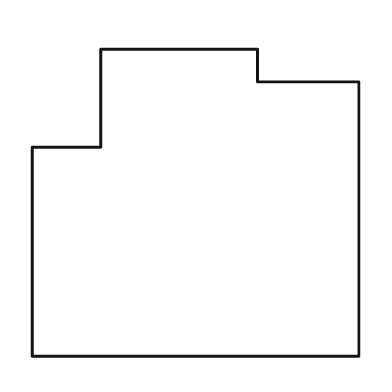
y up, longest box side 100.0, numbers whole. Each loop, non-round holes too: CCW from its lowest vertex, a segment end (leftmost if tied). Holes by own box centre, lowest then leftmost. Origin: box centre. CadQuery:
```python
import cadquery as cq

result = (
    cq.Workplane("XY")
    .moveTo(-50.0, -47.0)
    .lineTo(50.0, -47.0)
    .lineTo(50.0, 37.0)
    .lineTo(19.0, 37.0)
    .lineTo(19.0, 47.0)
    .lineTo(-29.0, 47.0)
    .lineTo(-29.0, 17.0)
    .lineTo(-50.0, 17.0)
    .close()
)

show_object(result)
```